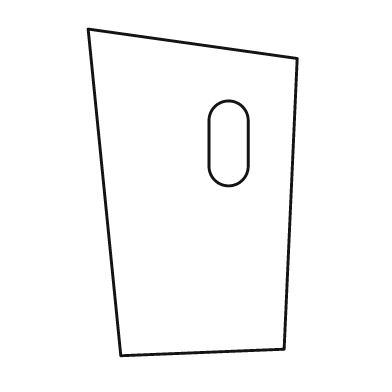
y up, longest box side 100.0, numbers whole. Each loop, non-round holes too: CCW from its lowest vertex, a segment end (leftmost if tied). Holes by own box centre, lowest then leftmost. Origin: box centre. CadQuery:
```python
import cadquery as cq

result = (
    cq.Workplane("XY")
    .moveTo(-22.0, -50.0)
    .lineTo(28.0, -48.0)
    .lineTo(32.0, 41.0)
    .lineTo(-32.0, 50.0)
    .close()
    .moveTo(5.0, 8.0)
    .threePointArc((11.0, 2.0), (17.0, 8.0))
    .lineTo(17.0, 22.0)
    .threePointArc((11.0, 28.0), (5.0, 22.0))
    .close()
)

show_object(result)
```